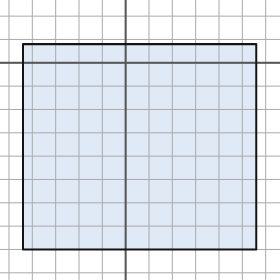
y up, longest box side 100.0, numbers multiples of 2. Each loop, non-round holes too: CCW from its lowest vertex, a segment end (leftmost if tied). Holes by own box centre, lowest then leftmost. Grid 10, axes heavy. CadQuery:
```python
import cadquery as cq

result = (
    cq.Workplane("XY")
    .moveTo(-44.0, -80.0)
    .lineTo(56.0, -80.0)
    .lineTo(56.0, 8.0)
    .lineTo(-44.0, 8.0)
    .close()
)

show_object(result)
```